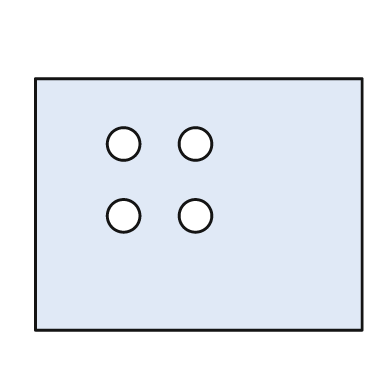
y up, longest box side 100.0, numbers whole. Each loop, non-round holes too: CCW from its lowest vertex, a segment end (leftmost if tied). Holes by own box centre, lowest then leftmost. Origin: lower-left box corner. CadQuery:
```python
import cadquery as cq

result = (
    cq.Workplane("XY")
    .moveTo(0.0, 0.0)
    .lineTo(100.0, 0.0)
    .lineTo(100.0, 77.0)
    .lineTo(0.0, 77.0)
    .close()
    .moveTo(27.0, 35.0)
    .circle(5.0)
    .moveTo(49.0, 35.0)
    .circle(5.0)
    .moveTo(27.0, 57.0)
    .circle(5.0)
    .moveTo(49.0, 57.0)
    .circle(5.0)
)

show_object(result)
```